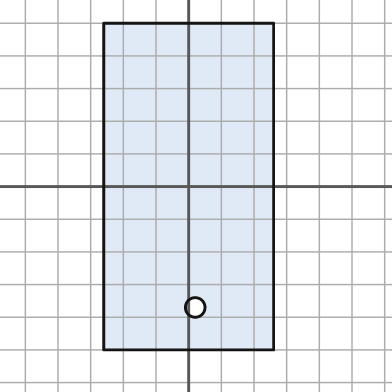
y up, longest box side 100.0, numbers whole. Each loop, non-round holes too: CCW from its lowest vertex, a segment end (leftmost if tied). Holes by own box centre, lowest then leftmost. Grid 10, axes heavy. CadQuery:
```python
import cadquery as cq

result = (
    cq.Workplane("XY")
    .moveTo(-26.0, -50.0)
    .lineTo(26.0, -50.0)
    .lineTo(26.0, 50.0)
    .lineTo(-26.0, 50.0)
    .close()
    .moveTo(2.0, -37.0)
    .circle(3.0)
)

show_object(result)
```